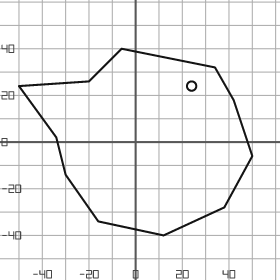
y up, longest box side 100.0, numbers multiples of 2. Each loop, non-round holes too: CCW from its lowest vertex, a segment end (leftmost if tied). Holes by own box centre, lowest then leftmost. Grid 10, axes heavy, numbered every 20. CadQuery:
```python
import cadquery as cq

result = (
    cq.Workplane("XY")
    .moveTo(12.0, -40.0)
    .lineTo(38.0, -28.0)
    .lineTo(50.0, -6.0)
    .lineTo(42.0, 18.0)
    .lineTo(34.0, 32.0)
    .lineTo(-6.0, 40.0)
    .lineTo(-20.0, 26.0)
    .lineTo(-50.0, 24.0)
    .lineTo(-34.0, 2.0)
    .lineTo(-30.0, -14.0)
    .lineTo(-16.0, -34.0)
    .close()
    .moveTo(24.0, 24.0)
    .circle(2.0)
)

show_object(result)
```